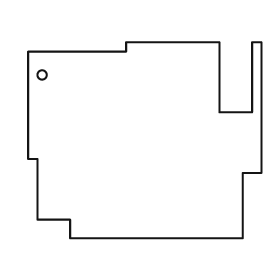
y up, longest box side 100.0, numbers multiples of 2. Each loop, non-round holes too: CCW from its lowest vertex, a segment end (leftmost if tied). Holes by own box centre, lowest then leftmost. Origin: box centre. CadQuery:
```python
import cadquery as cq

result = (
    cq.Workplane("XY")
    .moveTo(-32.0, -42.0)
    .lineTo(42.0, -42.0)
    .lineTo(42.0, -14.0)
    .lineTo(50.0, -14.0)
    .lineTo(50.0, 42.0)
    .lineTo(46.0, 42.0)
    .lineTo(46.0, 12.0)
    .lineTo(32.0, 12.0)
    .lineTo(32.0, 42.0)
    .lineTo(-8.0, 42.0)
    .lineTo(-8.0, 38.0)
    .lineTo(-50.0, 38.0)
    .lineTo(-50.0, -8.0)
    .lineTo(-46.0, -8.0)
    .lineTo(-46.0, -34.0)
    .lineTo(-32.0, -34.0)
    .close()
    .moveTo(-44.0, 28.0)
    .circle(2.0)
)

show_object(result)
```